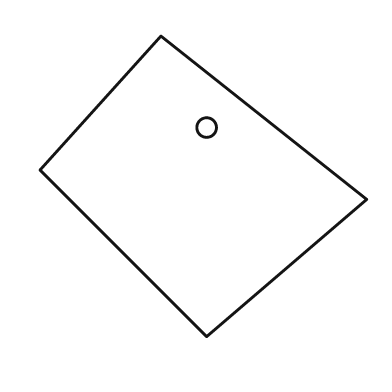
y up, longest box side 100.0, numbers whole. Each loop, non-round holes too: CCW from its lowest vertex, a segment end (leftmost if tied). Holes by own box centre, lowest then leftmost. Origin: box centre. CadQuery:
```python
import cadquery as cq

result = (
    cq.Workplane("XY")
    .moveTo(1.0, -46.0)
    .lineTo(50.0, -4.0)
    .lineTo(-13.0, 46.0)
    .lineTo(-50.0, 5.0)
    .close()
    .moveTo(1.0, 18.0)
    .circle(3.0)
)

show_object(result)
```